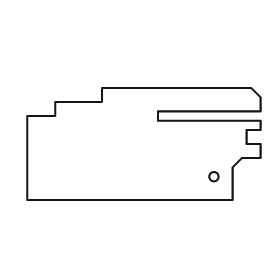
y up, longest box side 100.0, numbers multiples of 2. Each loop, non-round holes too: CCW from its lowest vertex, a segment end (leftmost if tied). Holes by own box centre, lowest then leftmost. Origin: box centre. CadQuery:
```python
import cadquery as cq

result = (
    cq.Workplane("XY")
    .moveTo(-50.0, -24.0)
    .lineTo(38.0, -24.0)
    .lineTo(38.0, -10.0)
    .lineTo(42.0, -6.0)
    .lineTo(50.0, -6.0)
    .lineTo(50.0, 0.0)
    .lineTo(44.0, 0.0)
    .lineTo(44.0, 6.0)
    .lineTo(50.0, 6.0)
    .lineTo(50.0, 10.0)
    .lineTo(6.0, 10.0)
    .lineTo(6.0, 14.0)
    .lineTo(50.0, 14.0)
    .lineTo(50.0, 20.0)
    .lineTo(46.0, 24.0)
    .lineTo(-18.0, 24.0)
    .lineTo(-18.0, 18.0)
    .lineTo(-38.0, 18.0)
    .lineTo(-38.0, 12.0)
    .lineTo(-50.0, 12.0)
    .close()
    .moveTo(30.0, -14.0)
    .circle(2.0)
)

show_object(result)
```